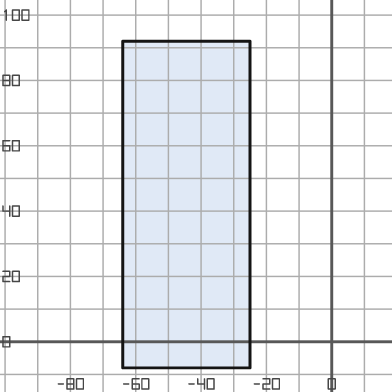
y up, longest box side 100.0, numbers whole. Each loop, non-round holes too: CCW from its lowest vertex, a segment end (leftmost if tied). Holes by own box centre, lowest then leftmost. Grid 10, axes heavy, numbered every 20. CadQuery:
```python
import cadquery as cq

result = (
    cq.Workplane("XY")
    .moveTo(-64.0, -8.0)
    .lineTo(-25.0, -8.0)
    .lineTo(-25.0, 92.0)
    .lineTo(-64.0, 92.0)
    .close()
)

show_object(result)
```